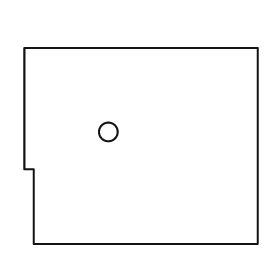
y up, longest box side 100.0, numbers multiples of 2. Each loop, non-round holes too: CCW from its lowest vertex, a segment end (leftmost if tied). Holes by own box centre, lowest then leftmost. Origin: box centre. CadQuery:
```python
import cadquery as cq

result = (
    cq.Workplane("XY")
    .moveTo(-46.0, -42.0)
    .lineTo(50.0, -42.0)
    .lineTo(50.0, 42.0)
    .lineTo(-50.0, 42.0)
    .lineTo(-50.0, -10.0)
    .lineTo(-46.0, -10.0)
    .close()
    .moveTo(-14.0, 6.0)
    .circle(4.0)
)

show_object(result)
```